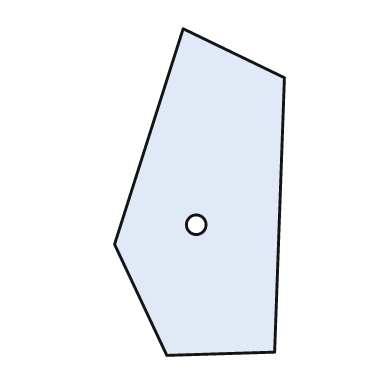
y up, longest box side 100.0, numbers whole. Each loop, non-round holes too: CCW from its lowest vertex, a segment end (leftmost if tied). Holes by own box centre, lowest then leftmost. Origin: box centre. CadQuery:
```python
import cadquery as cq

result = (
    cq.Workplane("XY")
    .moveTo(-10.0, -50.0)
    .lineTo(23.0, -49.0)
    .lineTo(26.0, 35.0)
    .lineTo(-5.0, 50.0)
    .lineTo(-26.0, -16.0)
    .close()
    .moveTo(-1.0, -10.0)
    .circle(3.0)
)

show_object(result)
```